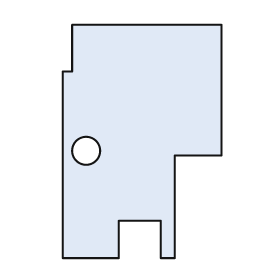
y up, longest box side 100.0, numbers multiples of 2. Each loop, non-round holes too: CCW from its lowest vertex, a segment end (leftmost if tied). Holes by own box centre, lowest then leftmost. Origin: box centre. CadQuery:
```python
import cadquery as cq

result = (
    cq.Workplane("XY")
    .moveTo(-34.0, -50.0)
    .lineTo(-10.0, -50.0)
    .lineTo(-10.0, -34.0)
    .lineTo(8.0, -34.0)
    .lineTo(8.0, -50.0)
    .lineTo(14.0, -50.0)
    .lineTo(14.0, -6.0)
    .lineTo(34.0, -6.0)
    .lineTo(34.0, 50.0)
    .lineTo(-30.0, 50.0)
    .lineTo(-30.0, 30.0)
    .lineTo(-34.0, 30.0)
    .close()
    .moveTo(-24.0, -4.0)
    .circle(6.0)
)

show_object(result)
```